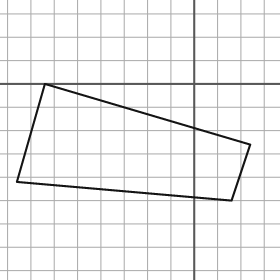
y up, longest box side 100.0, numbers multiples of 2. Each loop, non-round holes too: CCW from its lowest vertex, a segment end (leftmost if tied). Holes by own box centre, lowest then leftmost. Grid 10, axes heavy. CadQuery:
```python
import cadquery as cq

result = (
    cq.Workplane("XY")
    .moveTo(16.0, -50.0)
    .lineTo(24.0, -26.0)
    .lineTo(-64.0, 0.0)
    .lineTo(-76.0, -42.0)
    .close()
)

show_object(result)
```